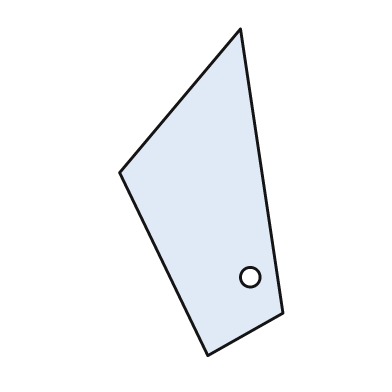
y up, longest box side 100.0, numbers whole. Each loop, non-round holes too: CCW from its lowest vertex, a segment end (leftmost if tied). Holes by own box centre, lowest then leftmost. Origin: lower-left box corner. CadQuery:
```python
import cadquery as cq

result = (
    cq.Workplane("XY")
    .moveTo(27.0, 0.0)
    .lineTo(50.0, 13.0)
    .lineTo(37.0, 100.0)
    .lineTo(0.0, 56.0)
    .close()
    .moveTo(40.0, 24.0)
    .circle(3.0)
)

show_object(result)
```